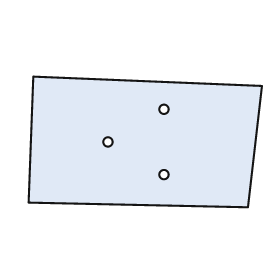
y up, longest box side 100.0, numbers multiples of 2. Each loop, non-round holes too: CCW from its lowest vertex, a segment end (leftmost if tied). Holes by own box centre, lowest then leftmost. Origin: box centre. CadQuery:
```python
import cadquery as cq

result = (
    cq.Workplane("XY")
    .moveTo(44.0, -28.0)
    .lineTo(50.0, 24.0)
    .lineTo(-48.0, 28.0)
    .lineTo(-50.0, -26.0)
    .close()
    .moveTo(8.0, -14.0)
    .circle(2.0)
    .moveTo(-16.0, 0.0)
    .circle(2.0)
    .moveTo(8.0, 14.0)
    .circle(2.0)
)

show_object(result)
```